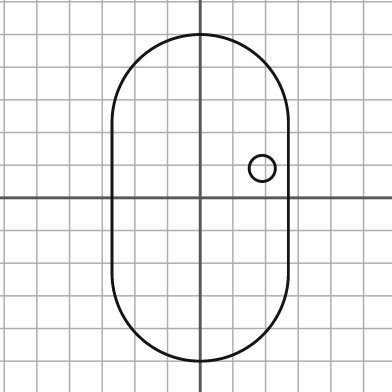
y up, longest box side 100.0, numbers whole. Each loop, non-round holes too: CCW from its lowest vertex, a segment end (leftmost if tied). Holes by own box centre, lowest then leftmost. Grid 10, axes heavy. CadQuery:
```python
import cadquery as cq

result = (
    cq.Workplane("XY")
    .moveTo(-27.0, -23.0)
    .threePointArc((0.0, -50.0), (27.0, -23.0))
    .lineTo(27.0, 23.0)
    .threePointArc((0.0, 50.0), (-27.0, 23.0))
    .close()
    .moveTo(19.0, 9.0)
    .circle(4.0)
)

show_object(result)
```